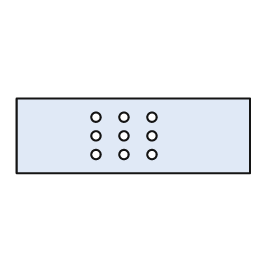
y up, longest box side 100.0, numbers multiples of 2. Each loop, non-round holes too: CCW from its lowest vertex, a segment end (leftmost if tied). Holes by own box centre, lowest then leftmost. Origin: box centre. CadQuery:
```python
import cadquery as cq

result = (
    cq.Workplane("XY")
    .moveTo(-50.0, -16.0)
    .lineTo(50.0, -16.0)
    .lineTo(50.0, 16.0)
    .lineTo(-50.0, 16.0)
    .close()
    .moveTo(-16.0, -8.0)
    .circle(2.0)
    .moveTo(-4.0, -8.0)
    .circle(2.0)
    .moveTo(8.0, -8.0)
    .circle(2.0)
    .moveTo(-16.0, 0.0)
    .circle(2.0)
    .moveTo(-4.0, 0.0)
    .circle(2.0)
    .moveTo(8.0, 0.0)
    .circle(2.0)
    .moveTo(-16.0, 8.0)
    .circle(2.0)
    .moveTo(-4.0, 8.0)
    .circle(2.0)
    .moveTo(8.0, 8.0)
    .circle(2.0)
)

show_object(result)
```